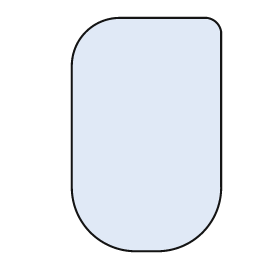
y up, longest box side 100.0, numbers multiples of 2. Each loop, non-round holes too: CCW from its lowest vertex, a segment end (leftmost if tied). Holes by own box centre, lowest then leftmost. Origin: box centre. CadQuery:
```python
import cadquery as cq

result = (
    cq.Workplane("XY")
    .moveTo(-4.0, -50.0)
    .lineTo(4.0, -50.0)
    .threePointArc((24.0, -42.0), (32.0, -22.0))
    .lineTo(32.0, 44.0)
    .threePointArc((30.0, 48.0), (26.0, 50.0))
    .lineTo(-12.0, 50.0)
    .threePointArc((-26.0, 44.0), (-32.0, 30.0))
    .lineTo(-32.0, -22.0)
    .threePointArc((-24.0, -42.0), (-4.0, -50.0))
    .close()
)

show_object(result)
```